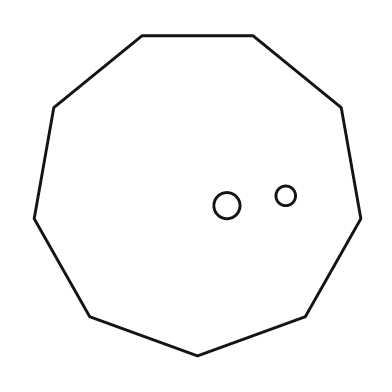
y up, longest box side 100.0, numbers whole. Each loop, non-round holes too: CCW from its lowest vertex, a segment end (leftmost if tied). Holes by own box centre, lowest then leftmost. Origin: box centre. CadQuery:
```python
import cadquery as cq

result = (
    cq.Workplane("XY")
    .moveTo(0.0, -49.0)
    .lineTo(33.0, -37.0)
    .lineTo(50.0, -7.0)
    .lineTo(44.0, 27.0)
    .lineTo(17.0, 49.0)
    .lineTo(-17.0, 49.0)
    .lineTo(-44.0, 27.0)
    .lineTo(-50.0, -7.0)
    .lineTo(-33.0, -37.0)
    .close()
    .moveTo(9.0, -3.0)
    .circle(4.0)
    .moveTo(27.0, 0.0)
    .circle(3.0)
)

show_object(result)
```